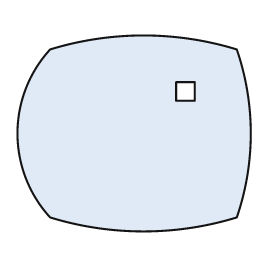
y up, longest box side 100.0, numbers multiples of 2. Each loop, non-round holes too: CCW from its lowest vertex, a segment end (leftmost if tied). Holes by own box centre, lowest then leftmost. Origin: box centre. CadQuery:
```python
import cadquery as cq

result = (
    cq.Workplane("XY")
    .moveTo(-36.0, -36.0)
    .threePointArc((4.0, -42.0), (44.0, -36.0))
    .threePointArc((50.0, 0.0), (44.0, 36.0))
    .threePointArc((4.0, 42.0), (-36.0, 36.0))
    .threePointArc((-50.0, 0.0), (-36.0, -36.0))
    .close()
    .moveTo(18.0, 14.0)
    .lineTo(26.0, 14.0)
    .lineTo(26.0, 22.0)
    .lineTo(18.0, 22.0)
    .close()
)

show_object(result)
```